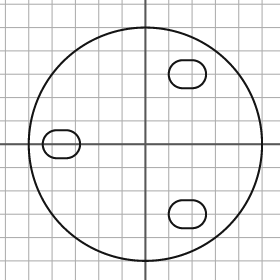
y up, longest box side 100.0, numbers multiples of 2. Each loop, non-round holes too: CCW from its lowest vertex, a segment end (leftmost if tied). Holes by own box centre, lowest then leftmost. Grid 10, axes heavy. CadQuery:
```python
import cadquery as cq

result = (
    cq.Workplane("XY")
    .moveTo(0.0, 0.0)
    .circle(50.0)
    .moveTo(16.0, -36.0)
    .lineTo(20.0, -36.0)
    .threePointArc((26.0, -30.0), (20.0, -24.0))
    .lineTo(16.0, -24.0)
    .threePointArc((10.0, -30.0), (16.0, -36.0))
    .close()
    .moveTo(-38.0, -6.0)
    .lineTo(-34.0, -6.0)
    .threePointArc((-28.0, 0.0), (-34.0, 6.0))
    .lineTo(-38.0, 6.0)
    .threePointArc((-44.0, 0.0), (-38.0, -6.0))
    .close()
    .moveTo(16.0, 24.0)
    .lineTo(20.0, 24.0)
    .threePointArc((26.0, 30.0), (20.0, 36.0))
    .lineTo(16.0, 36.0)
    .threePointArc((10.0, 30.0), (16.0, 24.0))
    .close()
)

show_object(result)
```